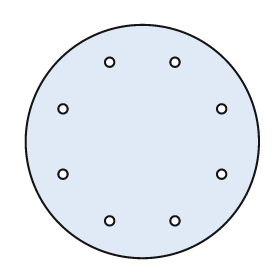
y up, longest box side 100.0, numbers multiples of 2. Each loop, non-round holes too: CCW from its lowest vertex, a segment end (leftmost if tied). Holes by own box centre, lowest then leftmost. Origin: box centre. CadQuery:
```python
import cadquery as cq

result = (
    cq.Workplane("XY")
    .moveTo(0.0, 0.0)
    .circle(50.0)
    .moveTo(-14.0, -34.0)
    .circle(2.0)
    .moveTo(14.0, -34.0)
    .circle(2.0)
    .moveTo(-34.0, -14.0)
    .circle(2.0)
    .moveTo(34.0, -14.0)
    .circle(2.0)
    .moveTo(-34.0, 14.0)
    .circle(2.0)
    .moveTo(34.0, 14.0)
    .circle(2.0)
    .moveTo(-14.0, 34.0)
    .circle(2.0)
    .moveTo(14.0, 34.0)
    .circle(2.0)
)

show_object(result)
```